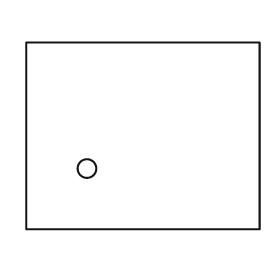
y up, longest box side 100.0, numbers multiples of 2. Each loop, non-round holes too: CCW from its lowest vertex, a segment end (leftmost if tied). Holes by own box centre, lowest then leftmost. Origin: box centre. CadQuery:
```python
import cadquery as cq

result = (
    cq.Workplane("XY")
    .moveTo(-50.0, -40.0)
    .lineTo(50.0, -40.0)
    .lineTo(50.0, 40.0)
    .lineTo(-50.0, 40.0)
    .close()
    .moveTo(-24.0, -14.0)
    .circle(4.0)
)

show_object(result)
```